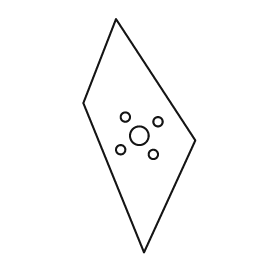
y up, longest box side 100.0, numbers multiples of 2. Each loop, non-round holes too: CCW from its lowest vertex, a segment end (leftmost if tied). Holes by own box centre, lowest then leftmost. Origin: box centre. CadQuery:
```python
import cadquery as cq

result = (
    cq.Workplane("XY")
    .moveTo(2.0, -50.0)
    .lineTo(24.0, -2.0)
    .lineTo(-10.0, 50.0)
    .lineTo(-24.0, 14.0)
    .close()
    .moveTo(6.0, -8.0)
    .circle(2.0)
    .moveTo(-8.0, -6.0)
    .circle(2.0)
    .moveTo(0.0, 0.0)
    .circle(4.0)
    .moveTo(8.0, 6.0)
    .circle(2.0)
    .moveTo(-6.0, 8.0)
    .circle(2.0)
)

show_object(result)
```